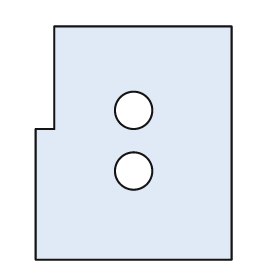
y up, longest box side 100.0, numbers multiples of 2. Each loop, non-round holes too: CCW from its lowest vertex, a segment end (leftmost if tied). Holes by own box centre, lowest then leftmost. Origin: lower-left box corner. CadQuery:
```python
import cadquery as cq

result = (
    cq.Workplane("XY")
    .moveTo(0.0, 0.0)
    .lineTo(84.0, 0.0)
    .lineTo(84.0, 100.0)
    .lineTo(8.0, 100.0)
    .lineTo(8.0, 56.0)
    .lineTo(0.0, 56.0)
    .close()
    .moveTo(42.0, 38.0)
    .circle(8.0)
    .moveTo(42.0, 64.0)
    .circle(8.0)
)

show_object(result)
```